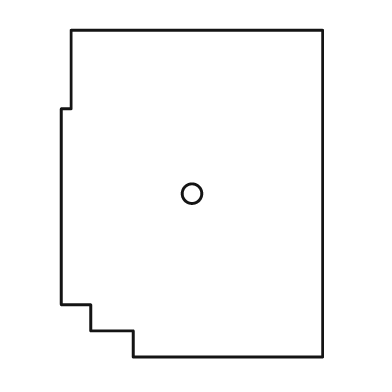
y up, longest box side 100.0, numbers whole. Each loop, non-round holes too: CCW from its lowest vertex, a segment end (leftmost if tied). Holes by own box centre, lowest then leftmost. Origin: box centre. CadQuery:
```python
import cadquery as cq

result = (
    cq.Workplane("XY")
    .moveTo(-18.0, -50.0)
    .lineTo(40.0, -50.0)
    .lineTo(40.0, 50.0)
    .lineTo(-37.0, 50.0)
    .lineTo(-37.0, 26.0)
    .lineTo(-40.0, 26.0)
    .lineTo(-40.0, -34.0)
    .lineTo(-31.0, -34.0)
    .lineTo(-31.0, -42.0)
    .lineTo(-18.0, -42.0)
    .close()
    .moveTo(0.0, 0.0)
    .circle(3.0)
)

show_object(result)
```